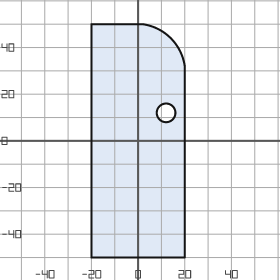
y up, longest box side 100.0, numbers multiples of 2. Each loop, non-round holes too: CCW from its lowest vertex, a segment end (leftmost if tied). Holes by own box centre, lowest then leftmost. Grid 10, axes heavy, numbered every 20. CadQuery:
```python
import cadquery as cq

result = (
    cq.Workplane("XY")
    .moveTo(-20.0, -50.0)
    .lineTo(20.0, -50.0)
    .lineTo(20.0, 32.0)
    .threePointArc((14.0, 44.0), (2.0, 50.0))
    .lineTo(-20.0, 50.0)
    .close()
    .moveTo(12.0, 12.0)
    .circle(4.0)
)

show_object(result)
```